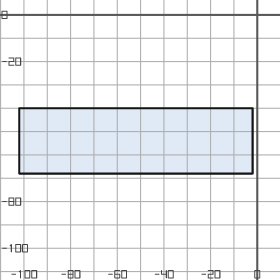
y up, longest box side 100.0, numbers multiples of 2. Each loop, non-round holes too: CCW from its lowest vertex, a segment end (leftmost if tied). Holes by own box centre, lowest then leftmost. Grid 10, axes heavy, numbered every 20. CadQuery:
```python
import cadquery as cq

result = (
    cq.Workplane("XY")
    .moveTo(-102.0, -68.0)
    .lineTo(-2.0, -68.0)
    .lineTo(-2.0, -40.0)
    .lineTo(-102.0, -40.0)
    .close()
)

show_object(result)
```